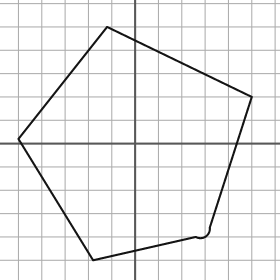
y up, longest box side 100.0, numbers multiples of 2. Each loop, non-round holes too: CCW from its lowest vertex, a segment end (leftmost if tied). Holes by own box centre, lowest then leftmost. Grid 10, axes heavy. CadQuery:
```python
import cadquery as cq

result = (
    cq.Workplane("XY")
    .moveTo(-18.0, -50.0)
    .lineTo(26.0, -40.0)
    .threePointArc((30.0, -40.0), (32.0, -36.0))
    .lineTo(50.0, 20.0)
    .lineTo(-12.0, 50.0)
    .lineTo(-50.0, 2.0)
    .close()
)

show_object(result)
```